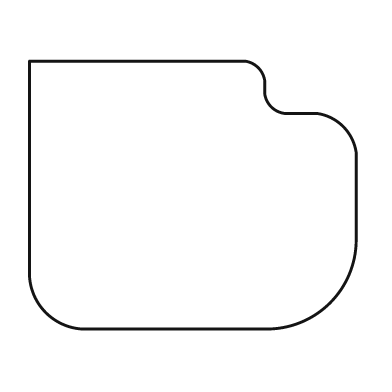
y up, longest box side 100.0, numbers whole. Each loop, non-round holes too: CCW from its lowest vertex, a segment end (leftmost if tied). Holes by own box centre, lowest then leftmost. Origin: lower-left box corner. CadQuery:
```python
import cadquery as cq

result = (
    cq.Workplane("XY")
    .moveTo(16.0, 0.0)
    .lineTo(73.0, 0.0)
    .threePointArc((92.0, 8.0), (100.0, 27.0))
    .lineTo(100.0, 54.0)
    .threePointArc((96.0, 62.0), (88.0, 66.0))
    .lineTo(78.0, 66.0)
    .threePointArc((74.0, 68.0), (72.0, 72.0))
    .lineTo(72.0, 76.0)
    .threePointArc((70.0, 80.0), (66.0, 82.0))
    .lineTo(0.0, 82.0)
    .lineTo(0.0, 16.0)
    .threePointArc((5.0, 5.0), (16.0, 0.0))
    .close()
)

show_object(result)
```